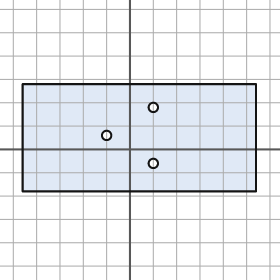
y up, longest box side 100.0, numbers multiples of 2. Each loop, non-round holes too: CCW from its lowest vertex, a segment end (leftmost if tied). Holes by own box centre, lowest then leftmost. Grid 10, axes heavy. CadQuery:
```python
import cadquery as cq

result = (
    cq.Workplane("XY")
    .moveTo(-46.0, -18.0)
    .lineTo(54.0, -18.0)
    .lineTo(54.0, 28.0)
    .lineTo(-46.0, 28.0)
    .close()
    .moveTo(10.0, -6.0)
    .circle(2.0)
    .moveTo(-10.0, 6.0)
    .circle(2.0)
    .moveTo(10.0, 18.0)
    .circle(2.0)
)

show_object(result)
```